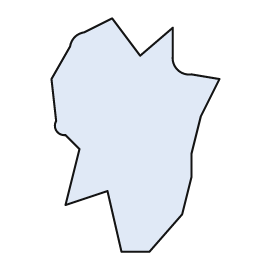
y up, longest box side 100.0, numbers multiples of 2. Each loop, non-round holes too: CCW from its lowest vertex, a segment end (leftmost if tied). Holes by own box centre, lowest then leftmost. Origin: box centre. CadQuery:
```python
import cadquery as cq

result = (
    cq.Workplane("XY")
    .moveTo(-6.0, -50.0)
    .lineTo(6.0, -50.0)
    .lineTo(20.0, -34.0)
    .lineTo(24.0, -18.0)
    .lineTo(24.0, -8.0)
    .lineTo(28.0, 8.0)
    .lineTo(36.0, 24.0)
    .lineTo(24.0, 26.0)
    .threePointArc((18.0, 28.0), (16.0, 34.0))
    .lineTo(16.0, 46.0)
    .lineTo(2.0, 34.0)
    .lineTo(-10.0, 50.0)
    .lineTo(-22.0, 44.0)
    .threePointArc((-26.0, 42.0), (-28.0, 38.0))
    .lineTo(-36.0, 24.0)
    .lineTo(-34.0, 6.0)
    .threePointArc((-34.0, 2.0), (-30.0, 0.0))
    .lineTo(-24.0, -6.0)
    .lineTo(-30.0, -30.0)
    .lineTo(-12.0, -24.0)
    .close()
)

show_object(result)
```